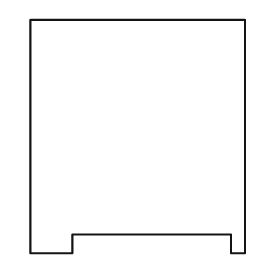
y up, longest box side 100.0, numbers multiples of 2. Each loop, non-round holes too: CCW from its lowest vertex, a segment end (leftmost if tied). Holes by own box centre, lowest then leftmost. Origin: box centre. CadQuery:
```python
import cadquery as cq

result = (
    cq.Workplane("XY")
    .moveTo(-46.0, -50.0)
    .lineTo(-28.0, -50.0)
    .lineTo(-28.0, -42.0)
    .lineTo(40.0, -42.0)
    .lineTo(40.0, -50.0)
    .lineTo(46.0, -50.0)
    .lineTo(46.0, 50.0)
    .lineTo(-46.0, 50.0)
    .close()
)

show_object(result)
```